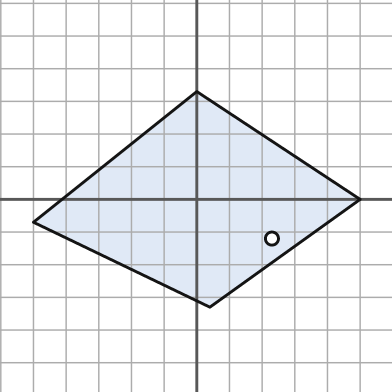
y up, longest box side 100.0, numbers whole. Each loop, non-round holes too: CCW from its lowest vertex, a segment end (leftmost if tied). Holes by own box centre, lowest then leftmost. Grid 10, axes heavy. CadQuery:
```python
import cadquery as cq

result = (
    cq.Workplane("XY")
    .moveTo(4.0, -33.0)
    .lineTo(50.0, 0.0)
    .lineTo(0.0, 33.0)
    .lineTo(-50.0, -7.0)
    .close()
    .moveTo(23.0, -12.0)
    .circle(2.0)
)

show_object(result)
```